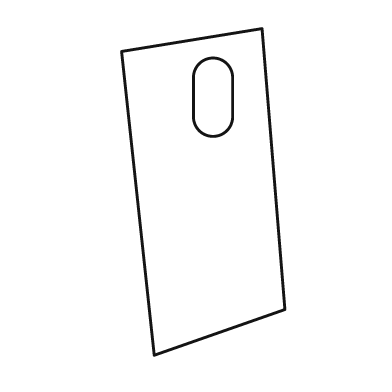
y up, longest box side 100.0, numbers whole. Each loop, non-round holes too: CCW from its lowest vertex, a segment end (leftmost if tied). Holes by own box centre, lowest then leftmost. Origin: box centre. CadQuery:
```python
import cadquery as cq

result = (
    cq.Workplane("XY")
    .moveTo(-15.0, -50.0)
    .lineTo(25.0, -36.0)
    .lineTo(18.0, 50.0)
    .lineTo(-25.0, 43.0)
    .close()
    .moveTo(-3.0, 23.0)
    .threePointArc((3.0, 17.0), (9.0, 23.0))
    .lineTo(9.0, 35.0)
    .threePointArc((3.0, 41.0), (-3.0, 35.0))
    .close()
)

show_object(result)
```